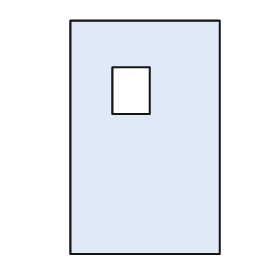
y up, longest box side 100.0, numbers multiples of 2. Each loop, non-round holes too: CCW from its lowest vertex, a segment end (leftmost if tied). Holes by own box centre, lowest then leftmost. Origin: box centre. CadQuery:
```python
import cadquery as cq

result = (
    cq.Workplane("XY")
    .moveTo(-32.0, -50.0)
    .lineTo(32.0, -50.0)
    .lineTo(32.0, 50.0)
    .lineTo(-32.0, 50.0)
    .close()
    .moveTo(-14.0, 10.0)
    .lineTo(2.0, 10.0)
    .lineTo(2.0, 30.0)
    .lineTo(-14.0, 30.0)
    .close()
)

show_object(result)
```